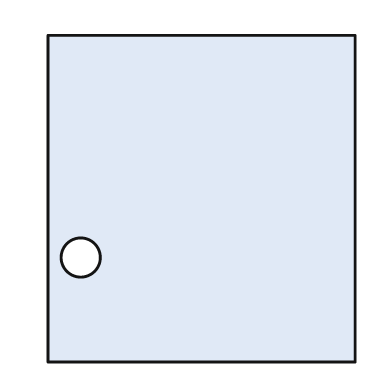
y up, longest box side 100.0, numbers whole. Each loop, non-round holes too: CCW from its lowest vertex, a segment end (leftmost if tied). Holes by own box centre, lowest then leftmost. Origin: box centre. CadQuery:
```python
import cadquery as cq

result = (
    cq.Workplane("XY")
    .moveTo(-47.0, -50.0)
    .lineTo(47.0, -50.0)
    .lineTo(47.0, 50.0)
    .lineTo(-47.0, 50.0)
    .close()
    .moveTo(-37.0, -18.0)
    .circle(6.0)
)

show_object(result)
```